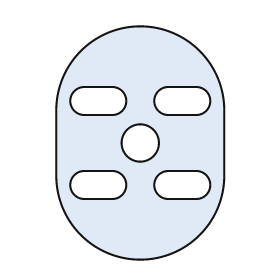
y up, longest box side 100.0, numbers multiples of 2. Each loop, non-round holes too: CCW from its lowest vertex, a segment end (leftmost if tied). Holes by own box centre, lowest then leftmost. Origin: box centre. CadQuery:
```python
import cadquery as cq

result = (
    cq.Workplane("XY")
    .moveTo(-36.0, -14.0)
    .threePointArc((0.0, -50.0), (36.0, -14.0))
    .lineTo(36.0, 14.0)
    .threePointArc((0.0, 50.0), (-36.0, 14.0))
    .close()
    .moveTo(-24.0, -24.0)
    .lineTo(-12.0, -24.0)
    .threePointArc((-6.0, -18.0), (-12.0, -12.0))
    .lineTo(-24.0, -12.0)
    .threePointArc((-30.0, -18.0), (-24.0, -24.0))
    .close()
    .moveTo(12.0, -24.0)
    .lineTo(24.0, -24.0)
    .threePointArc((30.0, -18.0), (24.0, -12.0))
    .lineTo(12.0, -12.0)
    .threePointArc((6.0, -18.0), (12.0, -24.0))
    .close()
    .moveTo(0.0, 0.0)
    .circle(8.0)
    .moveTo(-24.0, 12.0)
    .lineTo(-12.0, 12.0)
    .threePointArc((-6.0, 18.0), (-12.0, 24.0))
    .lineTo(-24.0, 24.0)
    .threePointArc((-30.0, 18.0), (-24.0, 12.0))
    .close()
    .moveTo(12.0, 12.0)
    .lineTo(24.0, 12.0)
    .threePointArc((30.0, 18.0), (24.0, 24.0))
    .lineTo(12.0, 24.0)
    .threePointArc((6.0, 18.0), (12.0, 12.0))
    .close()
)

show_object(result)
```